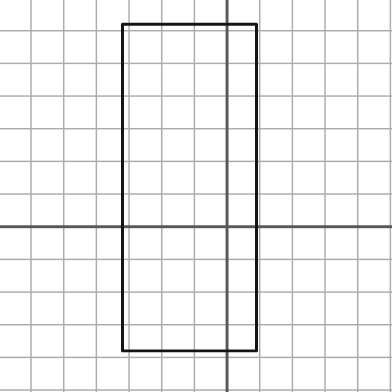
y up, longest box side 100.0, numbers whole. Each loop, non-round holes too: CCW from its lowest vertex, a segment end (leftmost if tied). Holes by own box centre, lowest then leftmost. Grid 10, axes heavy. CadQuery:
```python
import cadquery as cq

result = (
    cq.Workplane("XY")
    .moveTo(-32.0, -38.0)
    .lineTo(9.0, -38.0)
    .lineTo(9.0, 62.0)
    .lineTo(-32.0, 62.0)
    .close()
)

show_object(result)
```